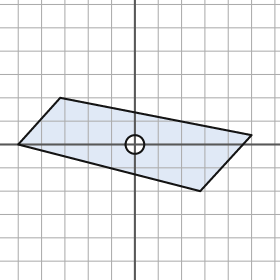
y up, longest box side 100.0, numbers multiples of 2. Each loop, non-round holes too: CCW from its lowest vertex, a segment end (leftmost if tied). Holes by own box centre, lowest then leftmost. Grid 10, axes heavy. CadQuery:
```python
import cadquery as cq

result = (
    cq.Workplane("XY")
    .moveTo(28.0, -20.0)
    .lineTo(50.0, 4.0)
    .lineTo(-32.0, 20.0)
    .lineTo(-50.0, 0.0)
    .close()
    .moveTo(0.0, 0.0)
    .circle(4.0)
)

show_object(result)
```